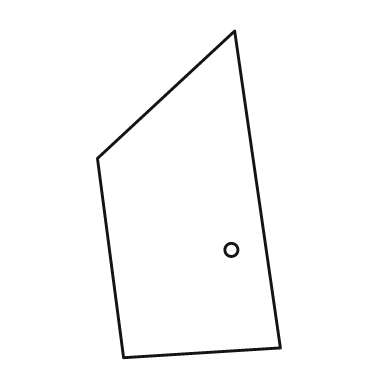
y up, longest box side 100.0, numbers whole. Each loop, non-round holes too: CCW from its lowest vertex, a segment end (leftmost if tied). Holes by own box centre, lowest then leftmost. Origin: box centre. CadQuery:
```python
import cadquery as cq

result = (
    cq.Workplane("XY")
    .moveTo(-20.0, -50.0)
    .lineTo(28.0, -47.0)
    .lineTo(14.0, 50.0)
    .lineTo(-28.0, 11.0)
    .close()
    .moveTo(13.0, -17.0)
    .circle(2.0)
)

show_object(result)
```